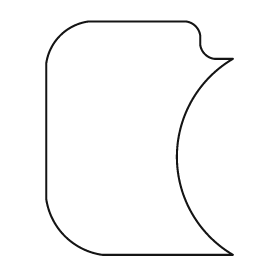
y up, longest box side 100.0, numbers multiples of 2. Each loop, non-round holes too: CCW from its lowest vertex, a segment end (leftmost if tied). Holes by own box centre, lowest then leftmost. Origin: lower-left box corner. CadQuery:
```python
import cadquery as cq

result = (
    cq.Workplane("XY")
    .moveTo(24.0, 0.0)
    .lineTo(80.0, 0.0)
    .threePointArc((56.0, 42.0), (80.0, 84.0))
    .lineTo(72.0, 84.0)
    .threePointArc((68.0, 86.0), (66.0, 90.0))
    .lineTo(66.0, 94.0)
    .threePointArc((64.0, 98.0), (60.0, 100.0))
    .lineTo(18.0, 100.0)
    .threePointArc((6.0, 94.0), (0.0, 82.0))
    .lineTo(0.0, 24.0)
    .threePointArc((8.0, 8.0), (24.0, 0.0))
    .close()
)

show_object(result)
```